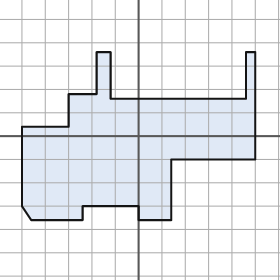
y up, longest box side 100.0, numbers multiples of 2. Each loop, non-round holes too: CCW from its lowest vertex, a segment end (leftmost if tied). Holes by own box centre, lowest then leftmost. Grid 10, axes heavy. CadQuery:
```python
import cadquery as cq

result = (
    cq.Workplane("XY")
    .moveTo(-46.0, -36.0)
    .lineTo(-24.0, -36.0)
    .lineTo(-24.0, -30.0)
    .lineTo(0.0, -30.0)
    .lineTo(0.0, -36.0)
    .lineTo(14.0, -36.0)
    .lineTo(14.0, -10.0)
    .lineTo(50.0, -10.0)
    .lineTo(50.0, 36.0)
    .lineTo(46.0, 36.0)
    .lineTo(46.0, 16.0)
    .lineTo(-12.0, 16.0)
    .lineTo(-12.0, 36.0)
    .lineTo(-18.0, 36.0)
    .lineTo(-18.0, 18.0)
    .lineTo(-30.0, 18.0)
    .lineTo(-30.0, 4.0)
    .lineTo(-50.0, 4.0)
    .lineTo(-50.0, -30.0)
    .close()
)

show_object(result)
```